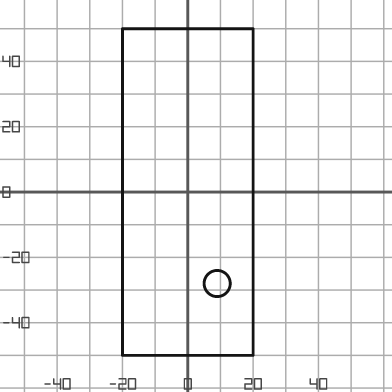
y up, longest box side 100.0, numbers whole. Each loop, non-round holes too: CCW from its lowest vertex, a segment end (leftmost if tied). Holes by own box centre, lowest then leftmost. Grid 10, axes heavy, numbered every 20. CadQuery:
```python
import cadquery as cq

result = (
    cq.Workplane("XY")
    .moveTo(-20.0, -50.0)
    .lineTo(20.0, -50.0)
    .lineTo(20.0, 50.0)
    .lineTo(-20.0, 50.0)
    .close()
    .moveTo(9.0, -28.0)
    .circle(4.0)
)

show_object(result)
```